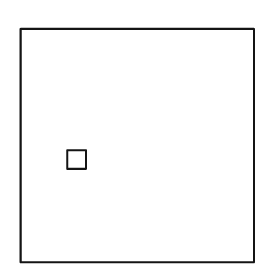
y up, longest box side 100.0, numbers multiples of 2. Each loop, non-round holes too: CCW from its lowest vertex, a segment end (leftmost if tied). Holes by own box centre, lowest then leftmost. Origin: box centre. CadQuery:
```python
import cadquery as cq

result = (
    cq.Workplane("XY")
    .moveTo(-50.0, -50.0)
    .lineTo(50.0, -50.0)
    .lineTo(50.0, 50.0)
    .lineTo(-50.0, 50.0)
    .close()
    .moveTo(-30.0, -10.0)
    .lineTo(-22.0, -10.0)
    .lineTo(-22.0, -2.0)
    .lineTo(-30.0, -2.0)
    .close()
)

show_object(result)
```